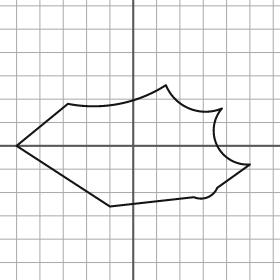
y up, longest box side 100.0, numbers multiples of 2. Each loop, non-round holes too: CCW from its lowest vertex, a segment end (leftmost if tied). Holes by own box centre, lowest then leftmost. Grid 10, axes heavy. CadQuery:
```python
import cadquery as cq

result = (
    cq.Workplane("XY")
    .moveTo(-10.0, -26.0)
    .lineTo(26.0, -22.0)
    .threePointArc((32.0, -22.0), (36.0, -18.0))
    .lineTo(50.0, -8.0)
    .threePointArc((36.0, 0.0), (38.0, 16.0))
    .threePointArc((24.0, 16.0), (14.0, 26.0))
    .threePointArc((-6.0, 18.0), (-28.0, 18.0))
    .lineTo(-50.0, 0.0)
    .close()
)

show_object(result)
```